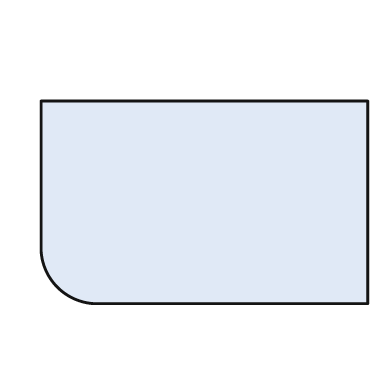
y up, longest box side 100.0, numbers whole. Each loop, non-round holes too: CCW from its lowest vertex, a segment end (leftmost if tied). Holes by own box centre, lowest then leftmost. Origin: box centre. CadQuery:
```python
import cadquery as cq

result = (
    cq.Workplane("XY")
    .moveTo(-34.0, -31.0)
    .lineTo(50.0, -31.0)
    .lineTo(50.0, 31.0)
    .lineTo(-50.0, 31.0)
    .lineTo(-50.0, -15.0)
    .threePointArc((-45.0, -26.0), (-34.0, -31.0))
    .close()
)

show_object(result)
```